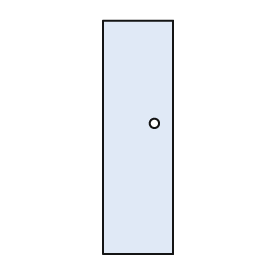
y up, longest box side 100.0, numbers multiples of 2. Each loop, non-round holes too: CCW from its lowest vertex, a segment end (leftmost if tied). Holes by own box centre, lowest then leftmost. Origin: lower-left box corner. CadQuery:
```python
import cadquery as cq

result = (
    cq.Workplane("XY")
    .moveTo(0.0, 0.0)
    .lineTo(30.0, 0.0)
    .lineTo(30.0, 100.0)
    .lineTo(0.0, 100.0)
    .close()
    .moveTo(22.0, 56.0)
    .circle(2.0)
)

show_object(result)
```